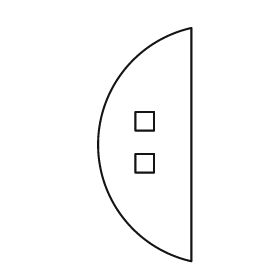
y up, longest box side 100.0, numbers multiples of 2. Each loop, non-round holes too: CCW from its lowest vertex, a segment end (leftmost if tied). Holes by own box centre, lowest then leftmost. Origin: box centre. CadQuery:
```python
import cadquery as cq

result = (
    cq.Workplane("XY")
    .moveTo(20.0, -50.0)
    .lineTo(20.0, 50.0)
    .threePointArc((-20.0, 0.0), (20.0, -50.0))
    .close()
    .moveTo(-4.0, -12.0)
    .lineTo(4.0, -12.0)
    .lineTo(4.0, -4.0)
    .lineTo(-4.0, -4.0)
    .close()
    .moveTo(-4.0, 6.0)
    .lineTo(4.0, 6.0)
    .lineTo(4.0, 14.0)
    .lineTo(-4.0, 14.0)
    .close()
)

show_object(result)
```